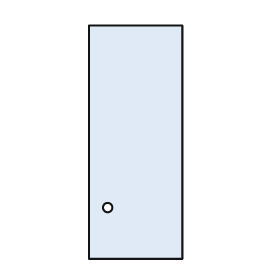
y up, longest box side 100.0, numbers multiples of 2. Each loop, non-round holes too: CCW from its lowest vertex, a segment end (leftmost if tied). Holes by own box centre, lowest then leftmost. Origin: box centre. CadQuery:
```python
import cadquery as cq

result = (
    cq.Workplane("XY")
    .moveTo(-20.0, -50.0)
    .lineTo(20.0, -50.0)
    .lineTo(20.0, 50.0)
    .lineTo(-20.0, 50.0)
    .close()
    .moveTo(-12.0, -28.0)
    .circle(2.0)
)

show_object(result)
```